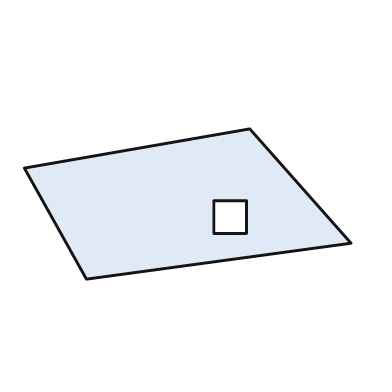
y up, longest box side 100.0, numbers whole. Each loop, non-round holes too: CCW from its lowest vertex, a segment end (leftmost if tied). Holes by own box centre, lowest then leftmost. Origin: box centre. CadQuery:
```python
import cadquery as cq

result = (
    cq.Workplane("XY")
    .moveTo(-31.0, -23.0)
    .lineTo(50.0, -12.0)
    .lineTo(19.0, 23.0)
    .lineTo(-50.0, 11.0)
    .close()
    .moveTo(8.0, -9.0)
    .lineTo(18.0, -9.0)
    .lineTo(18.0, 1.0)
    .lineTo(8.0, 1.0)
    .close()
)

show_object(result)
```